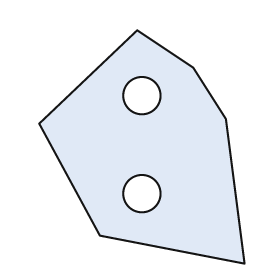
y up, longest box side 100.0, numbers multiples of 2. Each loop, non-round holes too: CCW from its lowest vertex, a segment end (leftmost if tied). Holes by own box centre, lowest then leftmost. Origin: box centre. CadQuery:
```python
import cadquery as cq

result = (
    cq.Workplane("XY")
    .moveTo(44.0, -50.0)
    .lineTo(36.0, 12.0)
    .lineTo(22.0, 34.0)
    .lineTo(-2.0, 50.0)
    .lineTo(-44.0, 10.0)
    .lineTo(-18.0, -38.0)
    .close()
    .moveTo(0.0, -20.0)
    .circle(8.0)
    .moveTo(0.0, 22.0)
    .circle(8.0)
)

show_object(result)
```